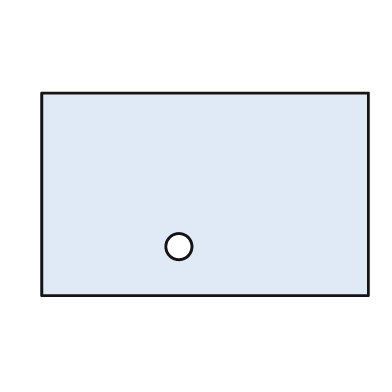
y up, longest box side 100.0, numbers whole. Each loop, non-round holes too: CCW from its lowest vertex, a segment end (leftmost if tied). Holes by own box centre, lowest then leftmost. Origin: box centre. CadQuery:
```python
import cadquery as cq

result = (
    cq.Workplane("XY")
    .moveTo(-50.0, -31.0)
    .lineTo(50.0, -31.0)
    .lineTo(50.0, 31.0)
    .lineTo(-50.0, 31.0)
    .close()
    .moveTo(-8.0, -16.0)
    .circle(4.0)
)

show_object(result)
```